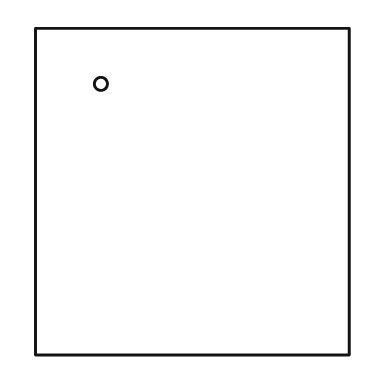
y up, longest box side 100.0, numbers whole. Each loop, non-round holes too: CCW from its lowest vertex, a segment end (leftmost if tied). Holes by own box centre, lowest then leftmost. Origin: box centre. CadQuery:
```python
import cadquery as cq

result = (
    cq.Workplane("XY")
    .moveTo(-48.0, -50.0)
    .lineTo(48.0, -50.0)
    .lineTo(48.0, 50.0)
    .lineTo(-48.0, 50.0)
    .close()
    .moveTo(-28.0, 33.0)
    .circle(2.0)
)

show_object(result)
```